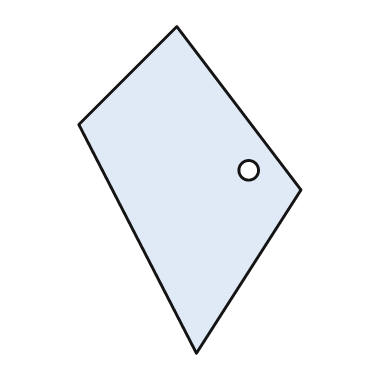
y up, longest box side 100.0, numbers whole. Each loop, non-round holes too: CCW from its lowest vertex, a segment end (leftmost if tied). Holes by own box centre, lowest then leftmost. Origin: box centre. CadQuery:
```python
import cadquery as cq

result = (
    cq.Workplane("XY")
    .moveTo(2.0, -50.0)
    .lineTo(34.0, 0.0)
    .lineTo(-4.0, 50.0)
    .lineTo(-34.0, 20.0)
    .close()
    .moveTo(18.0, 6.0)
    .circle(3.0)
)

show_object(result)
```